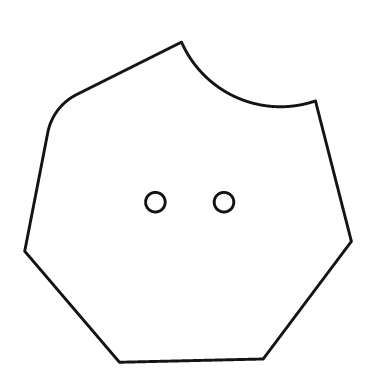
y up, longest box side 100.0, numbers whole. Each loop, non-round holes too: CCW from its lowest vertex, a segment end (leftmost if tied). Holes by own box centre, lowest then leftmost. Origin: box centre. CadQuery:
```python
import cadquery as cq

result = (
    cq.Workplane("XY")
    .moveTo(-21.0, -49.0)
    .lineTo(23.0, -48.0)
    .lineTo(50.0, -12.0)
    .lineTo(39.0, 31.0)
    .threePointArc((15.0, 32.0), (-2.0, 49.0))
    .lineTo(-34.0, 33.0)
    .threePointArc((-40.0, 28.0), (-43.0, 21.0))
    .lineTo(-50.0, -15.0)
    .close()
    .moveTo(-10.0, 0.0)
    .circle(3.0)
    .moveTo(11.0, 0.0)
    .circle(3.0)
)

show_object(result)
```